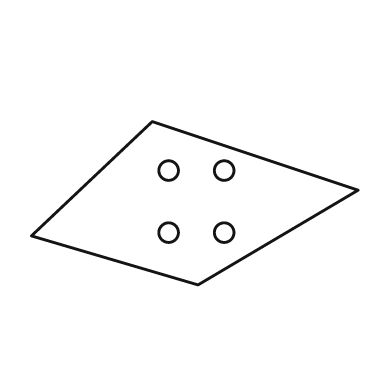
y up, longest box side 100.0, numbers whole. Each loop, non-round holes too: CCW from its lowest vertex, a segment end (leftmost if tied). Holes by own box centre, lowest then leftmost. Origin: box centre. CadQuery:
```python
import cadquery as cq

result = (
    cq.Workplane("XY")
    .moveTo(1.0, -25.0)
    .lineTo(50.0, 4.0)
    .lineTo(-13.0, 25.0)
    .lineTo(-50.0, -10.0)
    .close()
    .moveTo(-8.0, -9.0)
    .circle(3.0)
    .moveTo(9.0, -9.0)
    .circle(3.0)
    .moveTo(-8.0, 10.0)
    .circle(3.0)
    .moveTo(9.0, 10.0)
    .circle(3.0)
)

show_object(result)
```